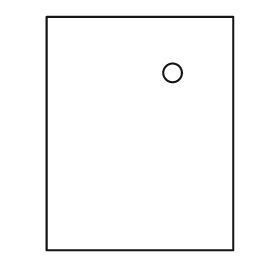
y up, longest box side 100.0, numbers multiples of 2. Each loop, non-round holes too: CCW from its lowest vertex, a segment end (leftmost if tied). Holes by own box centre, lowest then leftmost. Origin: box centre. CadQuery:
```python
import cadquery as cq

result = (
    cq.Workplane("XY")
    .moveTo(-40.0, -50.0)
    .lineTo(40.0, -50.0)
    .lineTo(40.0, 50.0)
    .lineTo(-40.0, 50.0)
    .close()
    .moveTo(14.0, 26.0)
    .circle(4.0)
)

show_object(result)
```